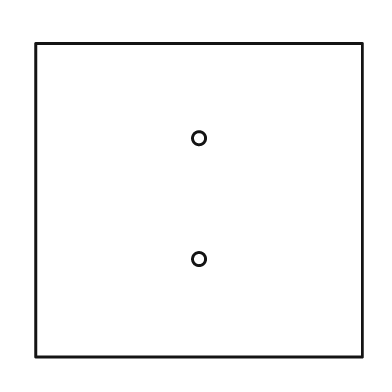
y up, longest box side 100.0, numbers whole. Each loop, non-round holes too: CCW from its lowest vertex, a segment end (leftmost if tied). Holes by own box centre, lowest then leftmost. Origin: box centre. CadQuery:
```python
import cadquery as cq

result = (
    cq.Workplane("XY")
    .moveTo(-50.0, -48.0)
    .lineTo(50.0, -48.0)
    .lineTo(50.0, 48.0)
    .lineTo(-50.0, 48.0)
    .close()
    .moveTo(0.0, -18.0)
    .circle(2.0)
    .moveTo(0.0, 19.0)
    .circle(2.0)
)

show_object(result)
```